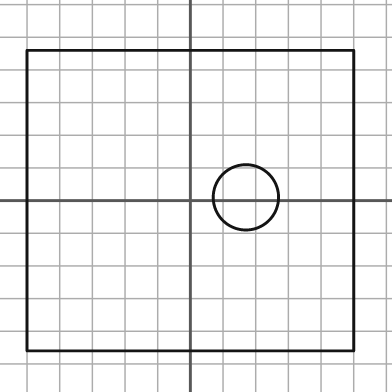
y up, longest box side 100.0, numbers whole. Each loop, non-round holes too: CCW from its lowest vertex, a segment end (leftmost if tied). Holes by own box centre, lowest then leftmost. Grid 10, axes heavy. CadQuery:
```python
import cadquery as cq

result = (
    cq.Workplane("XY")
    .moveTo(-50.0, -46.0)
    .lineTo(50.0, -46.0)
    .lineTo(50.0, 46.0)
    .lineTo(-50.0, 46.0)
    .close()
    .moveTo(17.0, 1.0)
    .circle(10.0)
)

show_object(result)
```